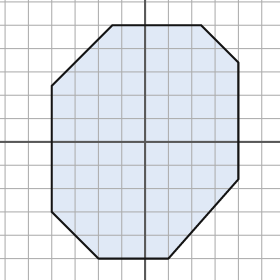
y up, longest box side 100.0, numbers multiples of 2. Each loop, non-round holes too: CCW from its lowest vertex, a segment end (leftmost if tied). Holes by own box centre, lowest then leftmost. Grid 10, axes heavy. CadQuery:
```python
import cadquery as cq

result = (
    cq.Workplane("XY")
    .moveTo(-20.0, -50.0)
    .lineTo(10.0, -50.0)
    .lineTo(40.0, -16.0)
    .lineTo(40.0, 34.0)
    .lineTo(24.0, 50.0)
    .lineTo(-14.0, 50.0)
    .lineTo(-40.0, 24.0)
    .lineTo(-40.0, -30.0)
    .close()
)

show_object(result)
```